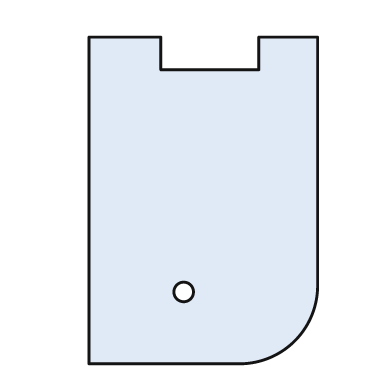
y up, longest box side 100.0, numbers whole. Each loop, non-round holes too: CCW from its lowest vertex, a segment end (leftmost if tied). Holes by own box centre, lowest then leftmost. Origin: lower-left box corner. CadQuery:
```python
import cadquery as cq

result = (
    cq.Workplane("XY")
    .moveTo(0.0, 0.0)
    .lineTo(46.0, 0.0)
    .threePointArc((63.0, 7.0), (70.0, 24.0))
    .lineTo(70.0, 100.0)
    .lineTo(52.0, 100.0)
    .lineTo(52.0, 90.0)
    .lineTo(22.0, 90.0)
    .lineTo(22.0, 100.0)
    .lineTo(0.0, 100.0)
    .close()
    .moveTo(29.0, 22.0)
    .circle(3.0)
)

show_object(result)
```